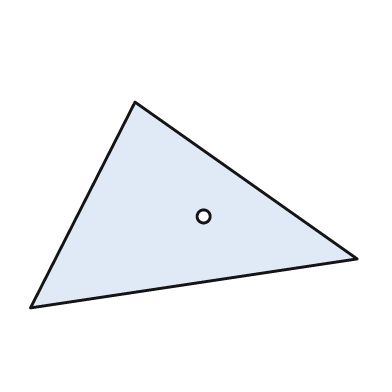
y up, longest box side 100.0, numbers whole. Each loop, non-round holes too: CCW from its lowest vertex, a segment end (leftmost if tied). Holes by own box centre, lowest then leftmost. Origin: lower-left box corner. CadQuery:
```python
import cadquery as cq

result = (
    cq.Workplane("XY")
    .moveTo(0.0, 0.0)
    .lineTo(100.0, 15.0)
    .lineTo(32.0, 63.0)
    .close()
    .moveTo(53.0, 28.0)
    .circle(2.0)
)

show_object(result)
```